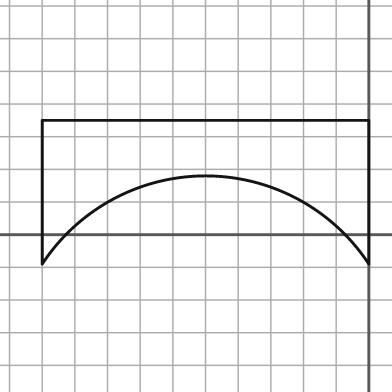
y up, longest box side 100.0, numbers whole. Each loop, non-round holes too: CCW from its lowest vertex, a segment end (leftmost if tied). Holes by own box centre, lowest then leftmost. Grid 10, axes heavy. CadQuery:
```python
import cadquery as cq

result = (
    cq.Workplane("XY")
    .moveTo(-100.0, -9.0)
    .threePointArc((-50.0, 18.0), (0.0, -9.0))
    .lineTo(0.0, 35.0)
    .lineTo(-100.0, 35.0)
    .close()
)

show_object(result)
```